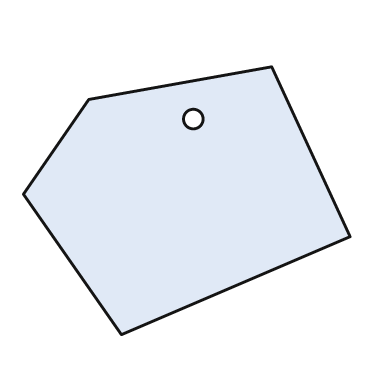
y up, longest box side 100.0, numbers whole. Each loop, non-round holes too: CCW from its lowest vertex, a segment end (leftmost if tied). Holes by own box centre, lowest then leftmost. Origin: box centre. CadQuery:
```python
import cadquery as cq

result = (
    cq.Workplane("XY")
    .moveTo(-20.0, -41.0)
    .lineTo(50.0, -11.0)
    .lineTo(26.0, 41.0)
    .lineTo(-30.0, 31.0)
    .lineTo(-50.0, 2.0)
    .close()
    .moveTo(2.0, 25.0)
    .circle(3.0)
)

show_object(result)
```